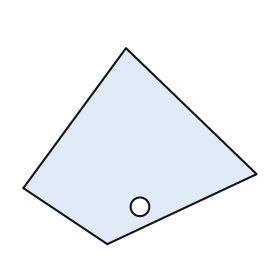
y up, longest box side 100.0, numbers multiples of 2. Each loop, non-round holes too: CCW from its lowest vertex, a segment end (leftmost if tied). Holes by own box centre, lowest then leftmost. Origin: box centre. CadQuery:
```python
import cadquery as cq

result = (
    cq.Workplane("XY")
    .moveTo(-14.0, -42.0)
    .lineTo(50.0, -12.0)
    .lineTo(-6.0, 42.0)
    .lineTo(-50.0, -18.0)
    .close()
    .moveTo(0.0, -26.0)
    .circle(4.0)
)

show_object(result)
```